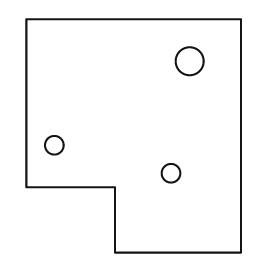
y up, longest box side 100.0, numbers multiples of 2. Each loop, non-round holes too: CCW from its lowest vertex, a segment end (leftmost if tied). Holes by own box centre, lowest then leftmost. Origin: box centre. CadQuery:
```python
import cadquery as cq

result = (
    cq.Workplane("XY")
    .moveTo(-8.0, -50.0)
    .lineTo(46.0, -50.0)
    .lineTo(46.0, 50.0)
    .lineTo(-46.0, 50.0)
    .lineTo(-46.0, -22.0)
    .lineTo(-8.0, -22.0)
    .close()
    .moveTo(16.0, -16.0)
    .circle(4.0)
    .moveTo(-34.0, -4.0)
    .circle(4.0)
    .moveTo(24.0, 32.0)
    .circle(6.0)
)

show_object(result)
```